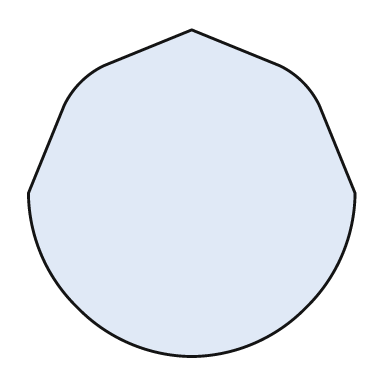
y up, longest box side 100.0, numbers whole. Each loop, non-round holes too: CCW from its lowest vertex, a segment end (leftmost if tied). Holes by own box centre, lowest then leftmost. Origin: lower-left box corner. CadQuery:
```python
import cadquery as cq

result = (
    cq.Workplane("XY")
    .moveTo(50.0, 0.0)
    .threePointArc((69.0, 4.0), (85.0, 15.0))
    .threePointArc((96.0, 31.0), (100.0, 50.0))
    .lineTo(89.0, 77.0)
    .threePointArc((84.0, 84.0), (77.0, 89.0))
    .lineTo(50.0, 100.0)
    .lineTo(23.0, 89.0)
    .threePointArc((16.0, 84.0), (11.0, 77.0))
    .lineTo(0.0, 50.0)
    .threePointArc((4.0, 31.0), (15.0, 15.0))
    .threePointArc((31.0, 4.0), (50.0, 0.0))
    .close()
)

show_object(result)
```